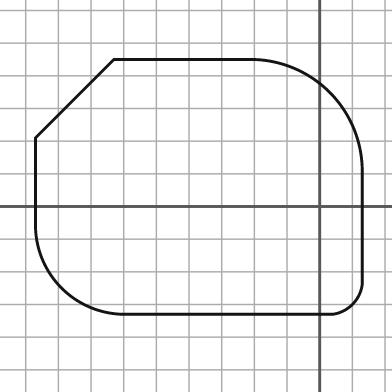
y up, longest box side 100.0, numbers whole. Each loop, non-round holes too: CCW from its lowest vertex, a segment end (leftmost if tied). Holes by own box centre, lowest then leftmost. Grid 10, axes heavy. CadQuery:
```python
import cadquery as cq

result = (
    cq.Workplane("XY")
    .moveTo(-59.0, -33.0)
    .lineTo(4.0, -33.0)
    .threePointArc((10.0, -30.0), (13.0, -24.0))
    .lineTo(13.0, 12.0)
    .threePointArc((3.0, 35.0), (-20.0, 45.0))
    .lineTo(-63.0, 45.0)
    .lineTo(-87.0, 21.0)
    .lineTo(-87.0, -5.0)
    .threePointArc((-79.0, -25.0), (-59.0, -33.0))
    .close()
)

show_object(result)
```